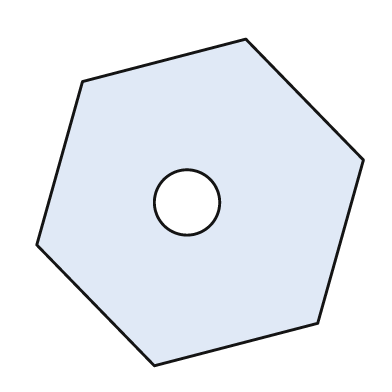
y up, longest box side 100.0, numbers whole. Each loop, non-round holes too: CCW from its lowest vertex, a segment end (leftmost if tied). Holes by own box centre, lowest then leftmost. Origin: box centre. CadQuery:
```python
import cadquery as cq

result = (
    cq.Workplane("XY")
    .moveTo(-14.0, -50.0)
    .lineTo(36.0, -37.0)
    .lineTo(50.0, 13.0)
    .lineTo(14.0, 50.0)
    .lineTo(-36.0, 37.0)
    .lineTo(-50.0, -13.0)
    .close()
    .moveTo(-4.0, 0.0)
    .circle(10.0)
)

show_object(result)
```